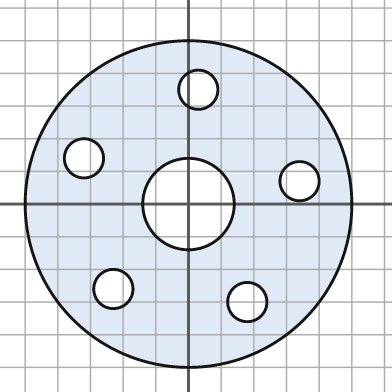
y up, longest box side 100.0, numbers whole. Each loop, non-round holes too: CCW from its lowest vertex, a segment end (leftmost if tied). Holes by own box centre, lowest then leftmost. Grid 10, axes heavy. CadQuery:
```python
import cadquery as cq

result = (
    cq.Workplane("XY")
    .moveTo(0.0, 0.0)
    .circle(50.0)
    .moveTo(18.0, -30.0)
    .circle(6.0)
    .moveTo(-23.0, -26.0)
    .circle(6.0)
    .moveTo(0.0, 0.0)
    .circle(14.0)
    .moveTo(34.0, 7.0)
    .circle(6.0)
    .moveTo(-32.0, 14.0)
    .circle(6.0)
    .moveTo(3.0, 35.0)
    .circle(6.0)
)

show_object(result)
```